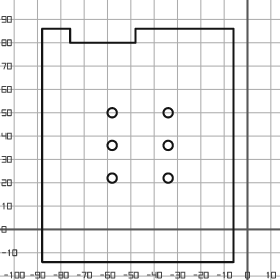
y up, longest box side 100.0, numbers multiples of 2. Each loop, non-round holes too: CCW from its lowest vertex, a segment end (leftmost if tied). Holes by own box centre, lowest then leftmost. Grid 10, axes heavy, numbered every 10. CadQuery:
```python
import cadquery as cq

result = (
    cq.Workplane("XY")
    .moveTo(-88.0, -14.0)
    .lineTo(-6.0, -14.0)
    .lineTo(-6.0, 86.0)
    .lineTo(-48.0, 86.0)
    .lineTo(-48.0, 80.0)
    .lineTo(-76.0, 80.0)
    .lineTo(-76.0, 86.0)
    .lineTo(-88.0, 86.0)
    .close()
    .moveTo(-58.0, 22.0)
    .circle(2.0)
    .moveTo(-34.0, 22.0)
    .circle(2.0)
    .moveTo(-58.0, 36.0)
    .circle(2.0)
    .moveTo(-34.0, 36.0)
    .circle(2.0)
    .moveTo(-58.0, 50.0)
    .circle(2.0)
    .moveTo(-34.0, 50.0)
    .circle(2.0)
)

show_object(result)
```